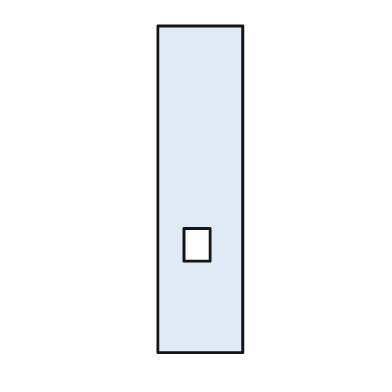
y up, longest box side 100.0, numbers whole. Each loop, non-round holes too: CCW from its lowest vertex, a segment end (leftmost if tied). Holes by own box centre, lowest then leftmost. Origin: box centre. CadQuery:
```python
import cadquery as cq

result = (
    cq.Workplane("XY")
    .moveTo(-13.0, -50.0)
    .lineTo(13.0, -50.0)
    .lineTo(13.0, 50.0)
    .lineTo(-13.0, 50.0)
    .close()
    .moveTo(-5.0, -22.0)
    .lineTo(3.0, -22.0)
    .lineTo(3.0, -12.0)
    .lineTo(-5.0, -12.0)
    .close()
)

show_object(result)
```